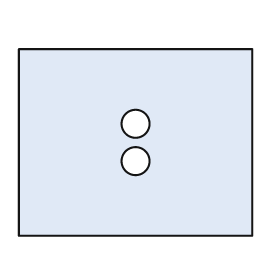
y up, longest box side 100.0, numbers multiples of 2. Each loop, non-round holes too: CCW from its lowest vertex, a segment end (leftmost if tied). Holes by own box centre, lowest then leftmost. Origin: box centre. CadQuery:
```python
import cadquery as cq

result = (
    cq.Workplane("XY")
    .moveTo(-50.0, -40.0)
    .lineTo(50.0, -40.0)
    .lineTo(50.0, 40.0)
    .lineTo(-50.0, 40.0)
    .close()
    .moveTo(0.0, -8.0)
    .circle(6.0)
    .moveTo(0.0, 8.0)
    .circle(6.0)
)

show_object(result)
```